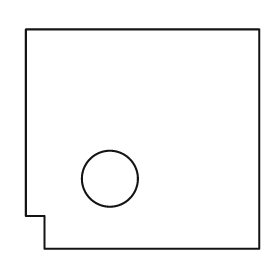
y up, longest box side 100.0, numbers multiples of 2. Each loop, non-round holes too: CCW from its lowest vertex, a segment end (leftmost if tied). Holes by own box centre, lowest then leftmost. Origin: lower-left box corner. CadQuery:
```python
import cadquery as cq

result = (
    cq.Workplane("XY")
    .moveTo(8.0, 0.0)
    .lineTo(100.0, 0.0)
    .lineTo(100.0, 94.0)
    .lineTo(0.0, 94.0)
    .lineTo(0.0, 14.0)
    .lineTo(8.0, 14.0)
    .close()
    .moveTo(36.0, 30.0)
    .circle(12.0)
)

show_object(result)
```